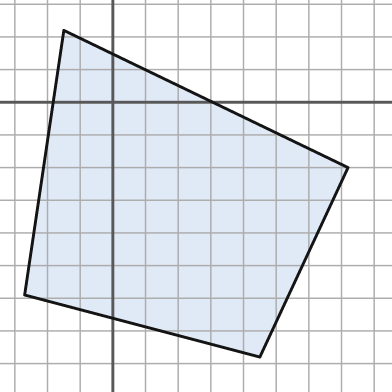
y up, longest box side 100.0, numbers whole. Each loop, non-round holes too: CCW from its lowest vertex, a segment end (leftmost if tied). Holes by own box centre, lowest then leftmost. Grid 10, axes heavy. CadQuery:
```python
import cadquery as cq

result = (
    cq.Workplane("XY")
    .moveTo(45.0, -78.0)
    .lineTo(72.0, -20.0)
    .lineTo(-15.0, 22.0)
    .lineTo(-27.0, -59.0)
    .close()
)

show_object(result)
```